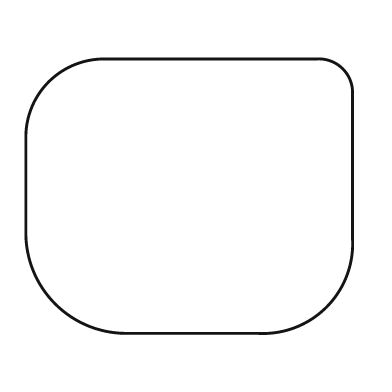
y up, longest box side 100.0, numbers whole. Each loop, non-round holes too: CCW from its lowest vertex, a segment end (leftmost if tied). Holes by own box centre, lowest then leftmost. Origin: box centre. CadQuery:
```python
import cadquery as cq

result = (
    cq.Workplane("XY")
    .moveTo(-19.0, -42.0)
    .lineTo(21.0, -42.0)
    .threePointArc((42.0, -34.0), (50.0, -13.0))
    .lineTo(50.0, 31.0)
    .threePointArc((47.0, 39.0), (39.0, 42.0))
    .lineTo(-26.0, 42.0)
    .threePointArc((-43.0, 35.0), (-50.0, 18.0))
    .lineTo(-50.0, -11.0)
    .threePointArc((-41.0, -33.0), (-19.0, -42.0))
    .close()
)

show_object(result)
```